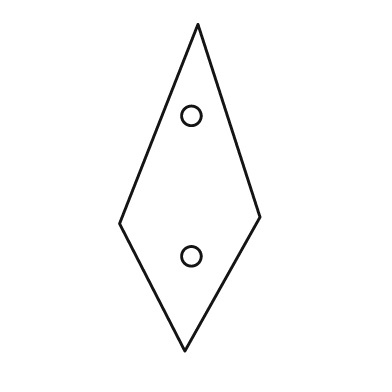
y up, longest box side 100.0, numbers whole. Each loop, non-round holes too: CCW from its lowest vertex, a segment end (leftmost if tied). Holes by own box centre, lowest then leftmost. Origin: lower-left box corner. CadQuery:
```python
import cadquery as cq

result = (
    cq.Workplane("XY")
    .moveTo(20.0, 0.0)
    .lineTo(43.0, 41.0)
    .lineTo(24.0, 100.0)
    .lineTo(0.0, 39.0)
    .close()
    .moveTo(22.0, 29.0)
    .circle(3.0)
    .moveTo(22.0, 72.0)
    .circle(3.0)
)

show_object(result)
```